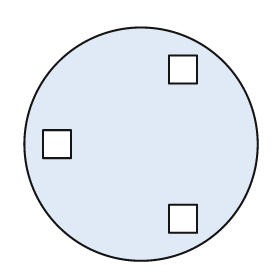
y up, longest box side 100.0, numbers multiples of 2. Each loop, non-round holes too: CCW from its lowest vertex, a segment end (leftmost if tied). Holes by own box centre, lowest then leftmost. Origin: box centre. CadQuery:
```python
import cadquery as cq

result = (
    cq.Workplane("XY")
    .moveTo(0.0, 0.0)
    .circle(50.0)
    .moveTo(12.0, -38.0)
    .lineTo(24.0, -38.0)
    .lineTo(24.0, -26.0)
    .lineTo(12.0, -26.0)
    .close()
    .moveTo(-42.0, -6.0)
    .lineTo(-30.0, -6.0)
    .lineTo(-30.0, 6.0)
    .lineTo(-42.0, 6.0)
    .close()
    .moveTo(12.0, 26.0)
    .lineTo(24.0, 26.0)
    .lineTo(24.0, 38.0)
    .lineTo(12.0, 38.0)
    .close()
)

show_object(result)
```